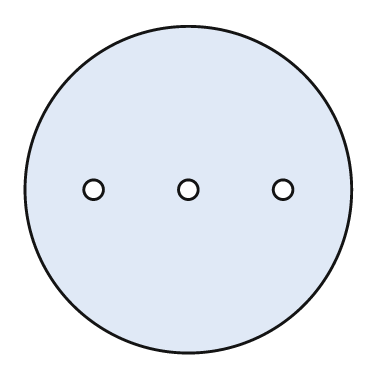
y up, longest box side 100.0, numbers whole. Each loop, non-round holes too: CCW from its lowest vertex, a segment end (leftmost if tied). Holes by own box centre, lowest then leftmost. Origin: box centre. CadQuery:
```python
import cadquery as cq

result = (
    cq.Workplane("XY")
    .moveTo(0.0, 0.0)
    .circle(50.0)
    .moveTo(-29.0, 0.0)
    .circle(3.0)
    .moveTo(0.0, 0.0)
    .circle(3.0)
    .moveTo(29.0, 0.0)
    .circle(3.0)
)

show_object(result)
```